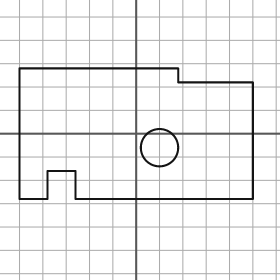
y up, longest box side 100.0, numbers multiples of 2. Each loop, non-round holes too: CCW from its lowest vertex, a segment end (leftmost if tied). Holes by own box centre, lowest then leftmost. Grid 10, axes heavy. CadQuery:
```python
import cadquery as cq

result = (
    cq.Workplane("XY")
    .moveTo(-50.0, -28.0)
    .lineTo(-38.0, -28.0)
    .lineTo(-38.0, -16.0)
    .lineTo(-26.0, -16.0)
    .lineTo(-26.0, -28.0)
    .lineTo(50.0, -28.0)
    .lineTo(50.0, 22.0)
    .lineTo(18.0, 22.0)
    .lineTo(18.0, 28.0)
    .lineTo(-50.0, 28.0)
    .close()
    .moveTo(10.0, -6.0)
    .circle(8.0)
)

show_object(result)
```